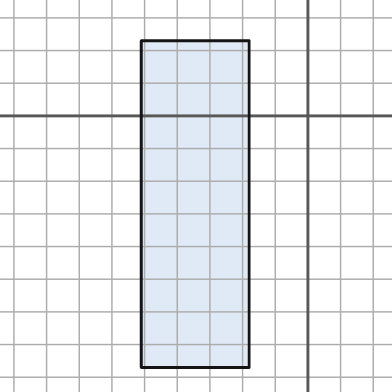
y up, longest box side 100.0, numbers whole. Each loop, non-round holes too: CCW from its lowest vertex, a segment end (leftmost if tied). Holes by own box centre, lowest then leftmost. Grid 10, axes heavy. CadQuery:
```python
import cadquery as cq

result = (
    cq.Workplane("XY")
    .moveTo(-51.0, -77.0)
    .lineTo(-18.0, -77.0)
    .lineTo(-18.0, 23.0)
    .lineTo(-51.0, 23.0)
    .close()
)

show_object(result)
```